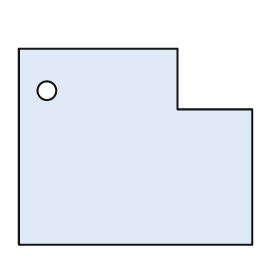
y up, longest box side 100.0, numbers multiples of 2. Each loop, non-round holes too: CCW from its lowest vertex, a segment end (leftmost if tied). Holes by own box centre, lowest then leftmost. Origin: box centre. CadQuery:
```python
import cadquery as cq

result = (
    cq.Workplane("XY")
    .moveTo(-50.0, -42.0)
    .lineTo(50.0, -42.0)
    .lineTo(50.0, 16.0)
    .lineTo(18.0, 16.0)
    .lineTo(18.0, 42.0)
    .lineTo(-50.0, 42.0)
    .close()
    .moveTo(-38.0, 24.0)
    .circle(4.0)
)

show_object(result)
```